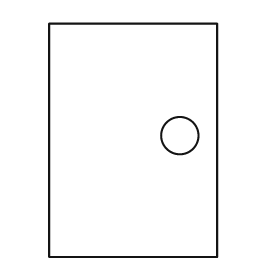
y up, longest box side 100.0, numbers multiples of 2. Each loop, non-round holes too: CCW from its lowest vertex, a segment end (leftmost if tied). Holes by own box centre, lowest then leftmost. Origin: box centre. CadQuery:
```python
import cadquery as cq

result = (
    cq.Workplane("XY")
    .moveTo(-36.0, -50.0)
    .lineTo(36.0, -50.0)
    .lineTo(36.0, 50.0)
    .lineTo(-36.0, 50.0)
    .close()
    .moveTo(20.0, 2.0)
    .circle(8.0)
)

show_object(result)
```